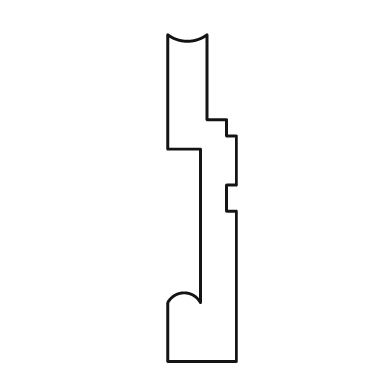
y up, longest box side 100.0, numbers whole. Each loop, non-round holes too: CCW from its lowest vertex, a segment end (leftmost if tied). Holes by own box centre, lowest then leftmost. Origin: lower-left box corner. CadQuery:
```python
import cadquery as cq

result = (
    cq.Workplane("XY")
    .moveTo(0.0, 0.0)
    .lineTo(21.0, 0.0)
    .lineTo(21.0, 46.0)
    .lineTo(18.0, 46.0)
    .lineTo(18.0, 54.0)
    .lineTo(21.0, 54.0)
    .lineTo(21.0, 69.0)
    .lineTo(18.0, 69.0)
    .lineTo(18.0, 74.0)
    .lineTo(12.0, 74.0)
    .lineTo(12.0, 100.0)
    .threePointArc((6.0, 98.0), (0.0, 100.0))
    .lineTo(0.0, 65.0)
    .lineTo(10.0, 65.0)
    .lineTo(10.0, 18.0)
    .threePointArc((5.0, 21.0), (0.0, 18.0))
    .close()
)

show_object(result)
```